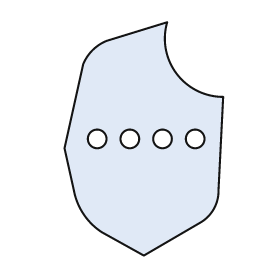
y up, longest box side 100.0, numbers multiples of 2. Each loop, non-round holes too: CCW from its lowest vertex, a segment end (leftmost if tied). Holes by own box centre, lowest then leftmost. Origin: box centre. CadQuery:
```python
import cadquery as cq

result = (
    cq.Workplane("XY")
    .moveTo(0.0, -50.0)
    .lineTo(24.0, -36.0)
    .threePointArc((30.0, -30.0), (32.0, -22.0))
    .lineTo(34.0, 18.0)
    .threePointArc((14.0, 28.0), (10.0, 50.0))
    .lineTo(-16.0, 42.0)
    .threePointArc((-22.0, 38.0), (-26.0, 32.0))
    .lineTo(-34.0, -4.0)
    .lineTo(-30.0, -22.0)
    .threePointArc((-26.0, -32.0), (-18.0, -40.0))
    .close()
    .moveTo(-20.0, 0.0)
    .circle(4.0)
    .moveTo(-6.0, 0.0)
    .circle(4.0)
    .moveTo(8.0, 0.0)
    .circle(4.0)
    .moveTo(22.0, 0.0)
    .circle(4.0)
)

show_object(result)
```